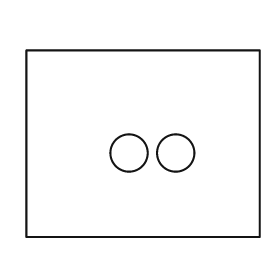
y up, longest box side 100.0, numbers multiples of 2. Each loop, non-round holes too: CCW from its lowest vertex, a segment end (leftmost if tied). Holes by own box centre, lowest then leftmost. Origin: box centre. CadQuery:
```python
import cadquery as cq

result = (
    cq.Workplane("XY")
    .moveTo(-50.0, -40.0)
    .lineTo(50.0, -40.0)
    .lineTo(50.0, 40.0)
    .lineTo(-50.0, 40.0)
    .close()
    .moveTo(-6.0, -4.0)
    .circle(8.0)
    .moveTo(14.0, -4.0)
    .circle(8.0)
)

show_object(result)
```